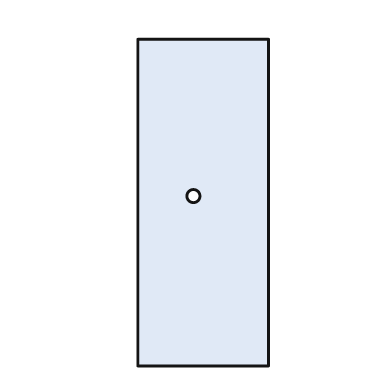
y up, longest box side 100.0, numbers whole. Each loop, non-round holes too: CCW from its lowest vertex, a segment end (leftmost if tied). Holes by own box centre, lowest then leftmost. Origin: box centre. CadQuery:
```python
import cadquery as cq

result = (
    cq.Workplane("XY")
    .moveTo(-20.0, -50.0)
    .lineTo(20.0, -50.0)
    .lineTo(20.0, 50.0)
    .lineTo(-20.0, 50.0)
    .close()
    .moveTo(-3.0, 2.0)
    .circle(2.0)
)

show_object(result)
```